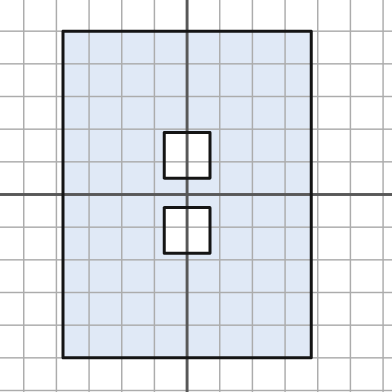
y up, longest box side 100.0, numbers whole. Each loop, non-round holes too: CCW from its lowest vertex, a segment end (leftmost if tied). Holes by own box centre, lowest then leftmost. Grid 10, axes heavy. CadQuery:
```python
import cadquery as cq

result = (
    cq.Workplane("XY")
    .moveTo(-38.0, -50.0)
    .lineTo(38.0, -50.0)
    .lineTo(38.0, 50.0)
    .lineTo(-38.0, 50.0)
    .close()
    .moveTo(-7.0, -18.0)
    .lineTo(7.0, -18.0)
    .lineTo(7.0, -4.0)
    .lineTo(-7.0, -4.0)
    .close()
    .moveTo(-7.0, 5.0)
    .lineTo(7.0, 5.0)
    .lineTo(7.0, 19.0)
    .lineTo(-7.0, 19.0)
    .close()
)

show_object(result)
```